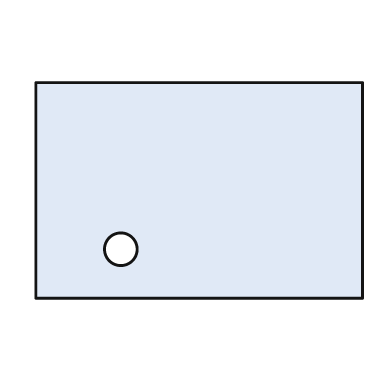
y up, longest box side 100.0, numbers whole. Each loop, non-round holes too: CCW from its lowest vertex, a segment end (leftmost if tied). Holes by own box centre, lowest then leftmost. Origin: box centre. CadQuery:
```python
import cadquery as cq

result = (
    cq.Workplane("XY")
    .moveTo(-50.0, -33.0)
    .lineTo(50.0, -33.0)
    .lineTo(50.0, 33.0)
    .lineTo(-50.0, 33.0)
    .close()
    .moveTo(-24.0, -18.0)
    .circle(5.0)
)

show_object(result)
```